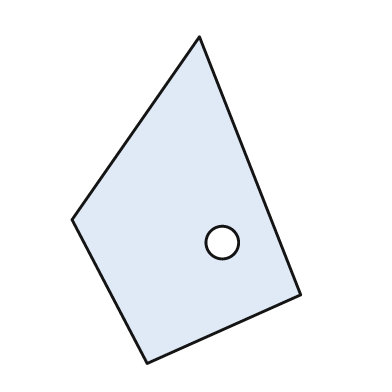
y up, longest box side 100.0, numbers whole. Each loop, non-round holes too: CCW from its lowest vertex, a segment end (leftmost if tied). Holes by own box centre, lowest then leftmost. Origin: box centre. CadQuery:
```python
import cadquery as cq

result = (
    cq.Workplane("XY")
    .moveTo(-12.0, -50.0)
    .lineTo(35.0, -29.0)
    .lineTo(4.0, 50.0)
    .lineTo(-35.0, -6.0)
    .close()
    .moveTo(11.0, -13.0)
    .circle(5.0)
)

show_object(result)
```